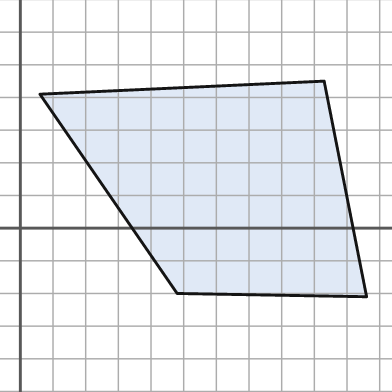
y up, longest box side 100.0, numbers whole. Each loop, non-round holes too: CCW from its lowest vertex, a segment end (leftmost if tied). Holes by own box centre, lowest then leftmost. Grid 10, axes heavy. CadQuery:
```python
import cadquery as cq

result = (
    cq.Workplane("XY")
    .moveTo(106.0, -21.0)
    .lineTo(93.0, 45.0)
    .lineTo(6.0, 41.0)
    .lineTo(48.0, -20.0)
    .close()
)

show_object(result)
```